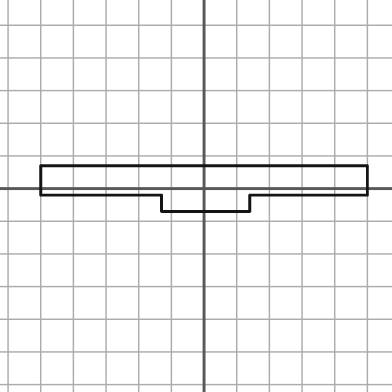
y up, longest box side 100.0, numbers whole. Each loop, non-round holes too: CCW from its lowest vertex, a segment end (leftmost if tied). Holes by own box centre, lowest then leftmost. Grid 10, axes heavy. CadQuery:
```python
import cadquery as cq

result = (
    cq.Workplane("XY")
    .moveTo(-13.0, -7.0)
    .lineTo(14.0, -7.0)
    .lineTo(14.0, -2.0)
    .lineTo(50.0, -2.0)
    .lineTo(50.0, 7.0)
    .lineTo(-50.0, 7.0)
    .lineTo(-50.0, -2.0)
    .lineTo(-13.0, -2.0)
    .close()
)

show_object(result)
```